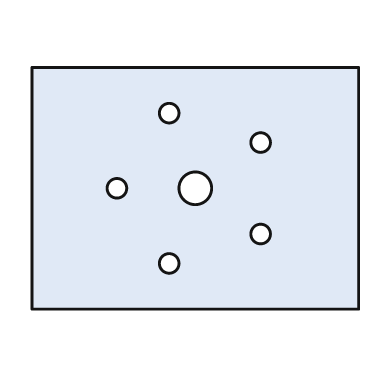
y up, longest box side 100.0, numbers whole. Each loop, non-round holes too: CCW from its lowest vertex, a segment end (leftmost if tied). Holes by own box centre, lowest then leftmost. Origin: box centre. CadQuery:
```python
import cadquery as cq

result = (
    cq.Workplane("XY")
    .moveTo(-50.0, -37.0)
    .lineTo(50.0, -37.0)
    .lineTo(50.0, 37.0)
    .lineTo(-50.0, 37.0)
    .close()
    .moveTo(-8.0, -23.0)
    .circle(3.0)
    .moveTo(20.0, -14.0)
    .circle(3.0)
    .moveTo(-24.0, 0.0)
    .circle(3.0)
    .moveTo(0.0, 0.0)
    .circle(5.0)
    .moveTo(20.0, 14.0)
    .circle(3.0)
    .moveTo(-8.0, 23.0)
    .circle(3.0)
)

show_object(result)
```